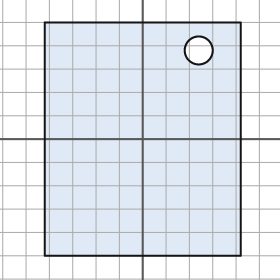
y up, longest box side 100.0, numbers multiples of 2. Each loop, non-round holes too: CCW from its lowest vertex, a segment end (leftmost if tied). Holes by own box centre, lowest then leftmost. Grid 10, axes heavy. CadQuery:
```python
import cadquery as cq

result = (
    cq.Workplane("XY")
    .moveTo(-42.0, -50.0)
    .lineTo(42.0, -50.0)
    .lineTo(42.0, 50.0)
    .lineTo(-42.0, 50.0)
    .close()
    .moveTo(24.0, 38.0)
    .circle(6.0)
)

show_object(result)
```